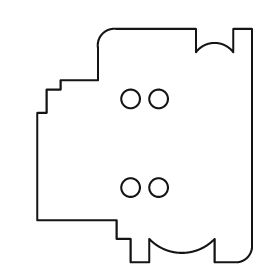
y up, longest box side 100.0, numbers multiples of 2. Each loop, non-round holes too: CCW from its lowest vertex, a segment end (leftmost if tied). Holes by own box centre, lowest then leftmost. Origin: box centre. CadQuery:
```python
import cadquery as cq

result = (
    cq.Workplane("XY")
    .moveTo(-6.0, -50.0)
    .lineTo(2.0, -50.0)
    .lineTo(2.0, -40.0)
    .threePointArc((16.0, -46.0), (30.0, -40.0))
    .lineTo(30.0, -50.0)
    .lineTo(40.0, -50.0)
    .threePointArc((44.0, -48.0), (46.0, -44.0))
    .lineTo(46.0, 50.0)
    .lineTo(38.0, 50.0)
    .lineTo(38.0, 40.0)
    .threePointArc((30.0, 44.0), (22.0, 40.0))
    .lineTo(22.0, 50.0)
    .lineTo(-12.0, 50.0)
    .threePointArc((-18.0, 48.0), (-20.0, 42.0))
    .lineTo(-20.0, 28.0)
    .lineTo(-36.0, 28.0)
    .lineTo(-36.0, 24.0)
    .lineTo(-42.0, 24.0)
    .lineTo(-42.0, 14.0)
    .lineTo(-46.0, 14.0)
    .lineTo(-46.0, -32.0)
    .lineTo(-12.0, -32.0)
    .lineTo(-12.0, -40.0)
    .lineTo(-6.0, -40.0)
    .close()
    .moveTo(-6.0, -18.0)
    .circle(4.0)
    .moveTo(6.0, -18.0)
    .circle(4.0)
    .moveTo(-6.0, 20.0)
    .circle(4.0)
    .moveTo(6.0, 20.0)
    .circle(4.0)
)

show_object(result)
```